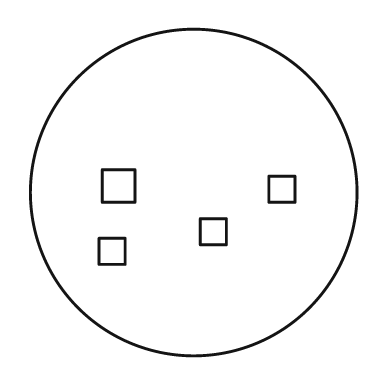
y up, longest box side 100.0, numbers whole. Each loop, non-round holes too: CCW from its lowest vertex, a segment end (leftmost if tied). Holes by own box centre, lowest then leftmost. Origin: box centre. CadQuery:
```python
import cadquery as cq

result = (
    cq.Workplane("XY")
    .moveTo(0.0, 0.0)
    .circle(50.0)
    .moveTo(-29.0, -22.0)
    .lineTo(-21.0, -22.0)
    .lineTo(-21.0, -14.0)
    .lineTo(-29.0, -14.0)
    .close()
    .moveTo(2.0, -16.0)
    .lineTo(10.0, -16.0)
    .lineTo(10.0, -8.0)
    .lineTo(2.0, -8.0)
    .close()
    .moveTo(23.0, -3.0)
    .lineTo(31.0, -3.0)
    .lineTo(31.0, 5.0)
    .lineTo(23.0, 5.0)
    .close()
    .moveTo(-28.0, -3.0)
    .lineTo(-18.0, -3.0)
    .lineTo(-18.0, 7.0)
    .lineTo(-28.0, 7.0)
    .close()
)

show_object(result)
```